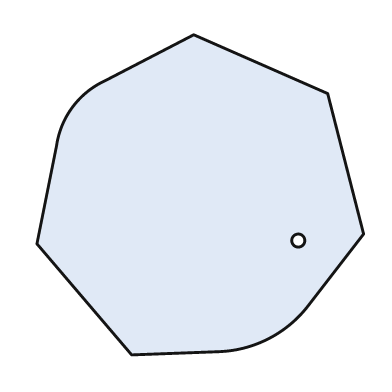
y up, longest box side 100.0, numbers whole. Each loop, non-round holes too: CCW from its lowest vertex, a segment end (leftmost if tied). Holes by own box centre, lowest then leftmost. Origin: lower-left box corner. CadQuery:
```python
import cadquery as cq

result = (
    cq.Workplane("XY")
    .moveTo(29.0, 0.0)
    .lineTo(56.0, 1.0)
    .threePointArc((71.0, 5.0), (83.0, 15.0))
    .lineTo(100.0, 37.0)
    .lineTo(89.0, 80.0)
    .lineTo(48.0, 98.0)
    .lineTo(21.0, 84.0)
    .threePointArc((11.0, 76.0), (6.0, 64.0))
    .lineTo(0.0, 34.0)
    .close()
    .moveTo(80.0, 35.0)
    .circle(2.0)
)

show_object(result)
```